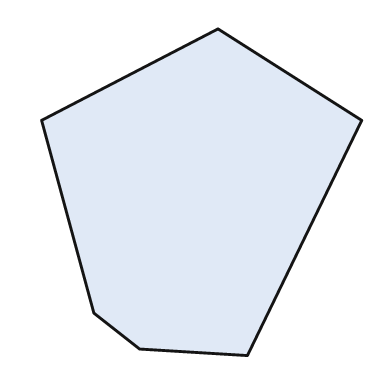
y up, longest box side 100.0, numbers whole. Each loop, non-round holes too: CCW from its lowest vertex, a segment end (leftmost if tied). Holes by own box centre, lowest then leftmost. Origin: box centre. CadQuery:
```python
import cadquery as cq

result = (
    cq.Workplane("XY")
    .moveTo(14.0, -50.0)
    .lineTo(49.0, 22.0)
    .lineTo(5.0, 50.0)
    .lineTo(-49.0, 22.0)
    .lineTo(-33.0, -37.0)
    .lineTo(-19.0, -48.0)
    .close()
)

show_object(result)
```